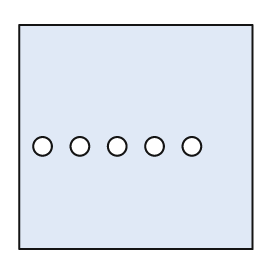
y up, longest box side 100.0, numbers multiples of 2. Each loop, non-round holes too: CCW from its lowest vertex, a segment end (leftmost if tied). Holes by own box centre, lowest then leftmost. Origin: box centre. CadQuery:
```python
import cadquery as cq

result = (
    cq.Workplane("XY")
    .moveTo(-50.0, -48.0)
    .lineTo(50.0, -48.0)
    .lineTo(50.0, 48.0)
    .lineTo(-50.0, 48.0)
    .close()
    .moveTo(-40.0, -4.0)
    .circle(4.0)
    .moveTo(-24.0, -4.0)
    .circle(4.0)
    .moveTo(-8.0, -4.0)
    .circle(4.0)
    .moveTo(8.0, -4.0)
    .circle(4.0)
    .moveTo(24.0, -4.0)
    .circle(4.0)
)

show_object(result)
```